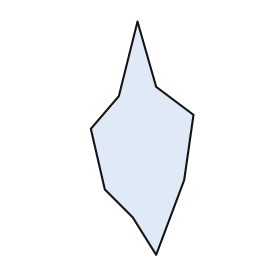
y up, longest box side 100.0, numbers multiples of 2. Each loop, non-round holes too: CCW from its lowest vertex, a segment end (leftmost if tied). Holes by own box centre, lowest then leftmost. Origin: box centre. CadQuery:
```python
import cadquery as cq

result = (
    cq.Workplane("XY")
    .moveTo(6.0, -50.0)
    .lineTo(18.0, -18.0)
    .lineTo(22.0, 10.0)
    .lineTo(6.0, 22.0)
    .lineTo(-2.0, 50.0)
    .lineTo(-10.0, 18.0)
    .lineTo(-22.0, 4.0)
    .lineTo(-16.0, -22.0)
    .lineTo(-4.0, -34.0)
    .close()
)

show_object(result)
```